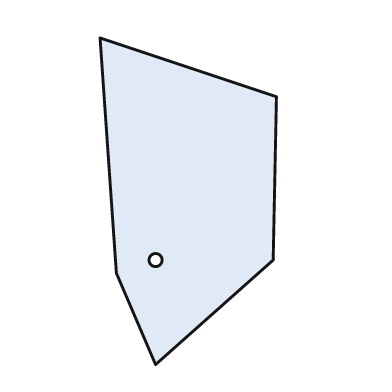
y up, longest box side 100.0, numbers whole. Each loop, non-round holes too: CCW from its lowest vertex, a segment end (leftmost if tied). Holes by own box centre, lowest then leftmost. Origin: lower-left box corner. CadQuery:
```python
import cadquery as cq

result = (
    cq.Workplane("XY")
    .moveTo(17.0, 0.0)
    .lineTo(53.0, 32.0)
    .lineTo(54.0, 82.0)
    .lineTo(0.0, 100.0)
    .lineTo(5.0, 28.0)
    .close()
    .moveTo(17.0, 32.0)
    .circle(2.0)
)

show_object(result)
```